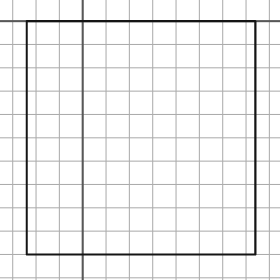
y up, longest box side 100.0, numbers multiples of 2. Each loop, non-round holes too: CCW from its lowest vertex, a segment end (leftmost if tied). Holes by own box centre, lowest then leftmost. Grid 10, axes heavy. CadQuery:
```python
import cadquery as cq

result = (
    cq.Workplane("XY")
    .moveTo(-24.0, -100.0)
    .lineTo(74.0, -100.0)
    .lineTo(74.0, 0.0)
    .lineTo(-24.0, 0.0)
    .close()
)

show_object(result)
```